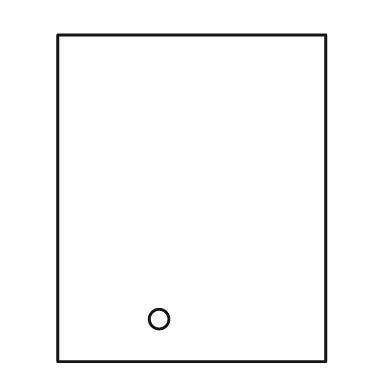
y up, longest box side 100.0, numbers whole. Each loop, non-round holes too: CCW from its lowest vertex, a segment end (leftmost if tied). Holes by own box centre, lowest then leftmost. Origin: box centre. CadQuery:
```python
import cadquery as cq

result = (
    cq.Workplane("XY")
    .moveTo(-41.0, -50.0)
    .lineTo(41.0, -50.0)
    .lineTo(41.0, 50.0)
    .lineTo(-41.0, 50.0)
    .close()
    .moveTo(-10.0, -37.0)
    .circle(3.0)
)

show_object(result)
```